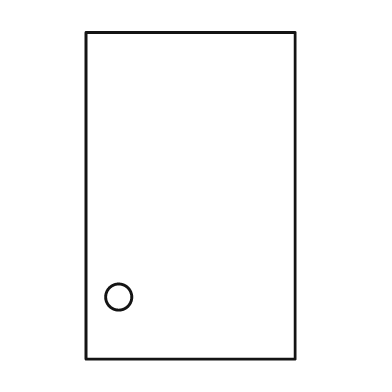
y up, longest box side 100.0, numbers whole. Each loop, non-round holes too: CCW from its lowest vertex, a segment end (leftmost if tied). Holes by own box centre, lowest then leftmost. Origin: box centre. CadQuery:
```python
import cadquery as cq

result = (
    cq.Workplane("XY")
    .moveTo(-32.0, -50.0)
    .lineTo(32.0, -50.0)
    .lineTo(32.0, 50.0)
    .lineTo(-32.0, 50.0)
    .close()
    .moveTo(-22.0, -31.0)
    .circle(4.0)
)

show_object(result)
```